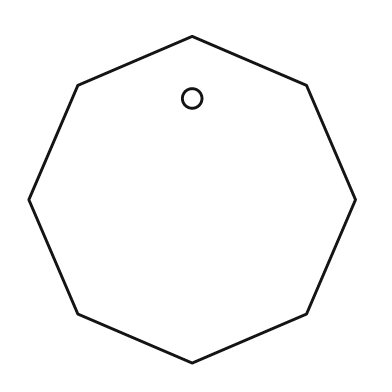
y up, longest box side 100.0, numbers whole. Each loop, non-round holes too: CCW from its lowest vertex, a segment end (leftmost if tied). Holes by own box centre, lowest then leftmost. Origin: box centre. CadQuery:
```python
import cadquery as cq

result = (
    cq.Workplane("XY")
    .moveTo(0.0, -50.0)
    .lineTo(35.0, -35.0)
    .lineTo(50.0, 0.0)
    .lineTo(35.0, 35.0)
    .lineTo(0.0, 50.0)
    .lineTo(-35.0, 35.0)
    .lineTo(-50.0, 0.0)
    .lineTo(-35.0, -35.0)
    .close()
    .moveTo(0.0, 31.0)
    .circle(3.0)
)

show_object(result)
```